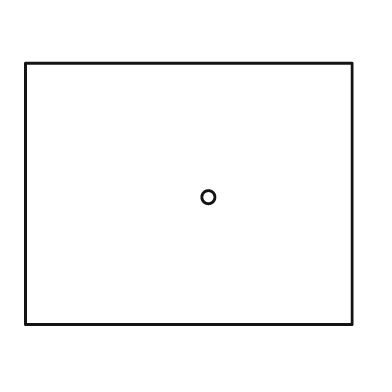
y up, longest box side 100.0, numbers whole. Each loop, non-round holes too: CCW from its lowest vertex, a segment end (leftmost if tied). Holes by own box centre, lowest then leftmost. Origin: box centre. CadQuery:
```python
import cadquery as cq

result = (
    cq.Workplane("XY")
    .moveTo(-50.0, -40.0)
    .lineTo(50.0, -40.0)
    .lineTo(50.0, 40.0)
    .lineTo(-50.0, 40.0)
    .close()
    .moveTo(6.0, -1.0)
    .circle(2.0)
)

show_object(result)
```